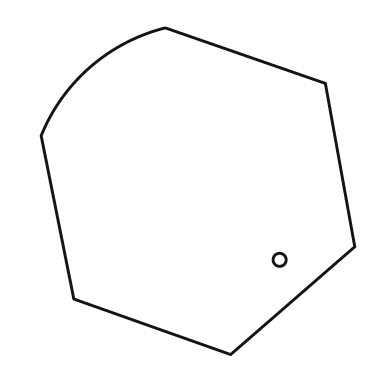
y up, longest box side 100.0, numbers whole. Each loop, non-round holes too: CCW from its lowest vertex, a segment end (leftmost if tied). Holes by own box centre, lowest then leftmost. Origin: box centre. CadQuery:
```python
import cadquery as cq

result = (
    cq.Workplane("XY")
    .moveTo(10.0, -50.0)
    .lineTo(48.0, -17.0)
    .lineTo(39.0, 33.0)
    .lineTo(-10.0, 50.0)
    .threePointArc((-33.0, 38.0), (-48.0, 17.0))
    .lineTo(-38.0, -33.0)
    .close()
    .moveTo(25.0, -21.0)
    .circle(2.0)
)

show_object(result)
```